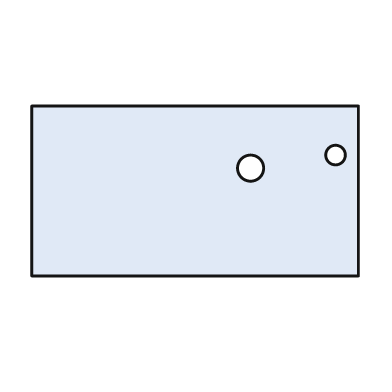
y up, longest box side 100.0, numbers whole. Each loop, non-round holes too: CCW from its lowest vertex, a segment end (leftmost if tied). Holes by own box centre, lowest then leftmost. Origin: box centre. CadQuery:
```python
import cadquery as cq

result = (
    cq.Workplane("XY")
    .moveTo(-50.0, -26.0)
    .lineTo(50.0, -26.0)
    .lineTo(50.0, 26.0)
    .lineTo(-50.0, 26.0)
    .close()
    .moveTo(17.0, 7.0)
    .circle(4.0)
    .moveTo(43.0, 11.0)
    .circle(3.0)
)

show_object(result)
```